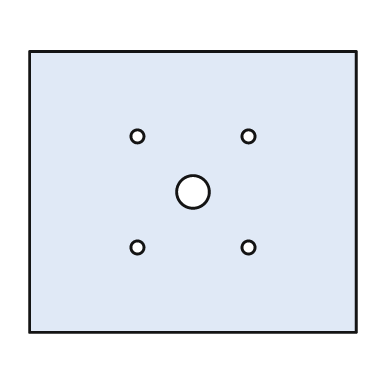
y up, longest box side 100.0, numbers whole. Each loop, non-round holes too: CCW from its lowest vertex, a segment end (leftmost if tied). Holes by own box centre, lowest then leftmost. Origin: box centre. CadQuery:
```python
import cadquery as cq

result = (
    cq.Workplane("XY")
    .moveTo(-50.0, -43.0)
    .lineTo(50.0, -43.0)
    .lineTo(50.0, 43.0)
    .lineTo(-50.0, 43.0)
    .close()
    .moveTo(-17.0, -17.0)
    .circle(2.0)
    .moveTo(17.0, -17.0)
    .circle(2.0)
    .moveTo(0.0, 0.0)
    .circle(5.0)
    .moveTo(-17.0, 17.0)
    .circle(2.0)
    .moveTo(17.0, 17.0)
    .circle(2.0)
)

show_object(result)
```